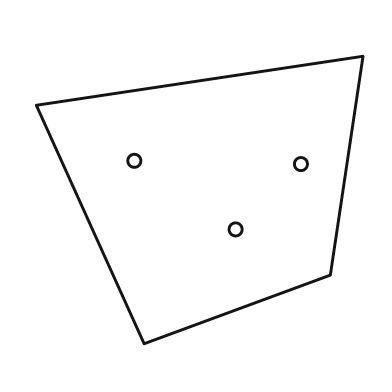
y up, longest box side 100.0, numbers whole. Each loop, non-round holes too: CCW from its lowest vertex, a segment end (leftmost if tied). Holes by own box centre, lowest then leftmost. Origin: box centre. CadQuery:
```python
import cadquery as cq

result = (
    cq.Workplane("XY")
    .moveTo(-17.0, -44.0)
    .lineTo(40.0, -23.0)
    .lineTo(50.0, 44.0)
    .lineTo(-50.0, 29.0)
    .close()
    .moveTo(11.0, -9.0)
    .circle(2.0)
    .moveTo(31.0, 11.0)
    .circle(2.0)
    .moveTo(-20.0, 12.0)
    .circle(2.0)
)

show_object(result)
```